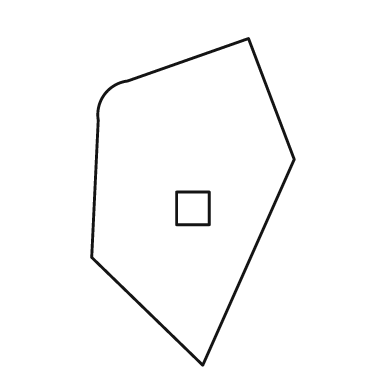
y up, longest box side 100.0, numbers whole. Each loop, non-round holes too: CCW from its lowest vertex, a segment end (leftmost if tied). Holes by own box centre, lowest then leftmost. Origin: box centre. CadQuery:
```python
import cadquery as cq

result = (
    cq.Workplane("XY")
    .moveTo(3.0, -50.0)
    .lineTo(31.0, 13.0)
    .lineTo(17.0, 50.0)
    .lineTo(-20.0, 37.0)
    .threePointArc((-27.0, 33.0), (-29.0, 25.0))
    .lineTo(-31.0, -17.0)
    .close()
    .moveTo(-5.0, -7.0)
    .lineTo(5.0, -7.0)
    .lineTo(5.0, 3.0)
    .lineTo(-5.0, 3.0)
    .close()
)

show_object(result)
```